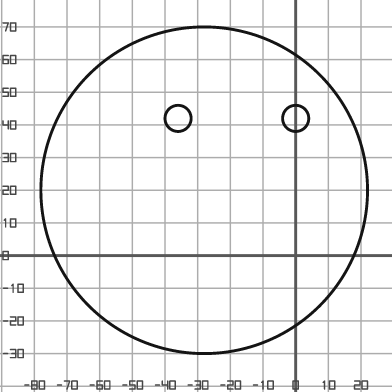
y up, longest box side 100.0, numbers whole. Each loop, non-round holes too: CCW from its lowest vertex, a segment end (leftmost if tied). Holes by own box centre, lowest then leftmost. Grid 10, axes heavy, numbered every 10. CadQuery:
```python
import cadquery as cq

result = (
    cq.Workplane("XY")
    .moveTo(-28.0, 20.0)
    .circle(50.0)
    .moveTo(-36.0, 42.0)
    .circle(4.0)
    .moveTo(0.0, 42.0)
    .circle(4.0)
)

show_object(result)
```